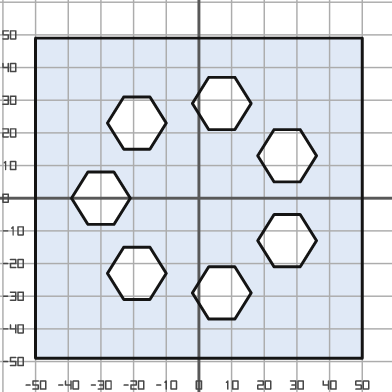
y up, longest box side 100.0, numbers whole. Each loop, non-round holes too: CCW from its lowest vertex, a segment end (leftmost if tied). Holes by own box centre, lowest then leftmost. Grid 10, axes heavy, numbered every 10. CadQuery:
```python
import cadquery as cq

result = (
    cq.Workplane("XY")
    .moveTo(-50.0, -49.0)
    .lineTo(50.0, -49.0)
    .lineTo(50.0, 49.0)
    .lineTo(-50.0, 49.0)
    .close()
    .moveTo(3.0, -37.0)
    .lineTo(11.0, -37.0)
    .lineTo(16.0, -29.0)
    .lineTo(11.0, -21.0)
    .lineTo(3.0, -21.0)
    .lineTo(-2.0, -29.0)
    .close()
    .moveTo(-23.0, -31.0)
    .lineTo(-15.0, -31.0)
    .lineTo(-10.0, -23.0)
    .lineTo(-15.0, -15.0)
    .lineTo(-23.0, -15.0)
    .lineTo(-28.0, -23.0)
    .close()
    .moveTo(23.0, -21.0)
    .lineTo(31.0, -21.0)
    .lineTo(36.0, -13.0)
    .lineTo(31.0, -5.0)
    .lineTo(23.0, -5.0)
    .lineTo(18.0, -13.0)
    .close()
    .moveTo(-34.0, -8.0)
    .lineTo(-26.0, -8.0)
    .lineTo(-21.0, 0.0)
    .lineTo(-26.0, 8.0)
    .lineTo(-34.0, 8.0)
    .lineTo(-39.0, 0.0)
    .close()
    .moveTo(23.0, 5.0)
    .lineTo(31.0, 5.0)
    .lineTo(36.0, 13.0)
    .lineTo(31.0, 21.0)
    .lineTo(23.0, 21.0)
    .lineTo(18.0, 13.0)
    .close()
    .moveTo(-23.0, 15.0)
    .lineTo(-15.0, 15.0)
    .lineTo(-10.0, 23.0)
    .lineTo(-15.0, 31.0)
    .lineTo(-23.0, 31.0)
    .lineTo(-28.0, 23.0)
    .close()
    .moveTo(3.0, 21.0)
    .lineTo(11.0, 21.0)
    .lineTo(16.0, 29.0)
    .lineTo(11.0, 37.0)
    .lineTo(3.0, 37.0)
    .lineTo(-2.0, 29.0)
    .close()
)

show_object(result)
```